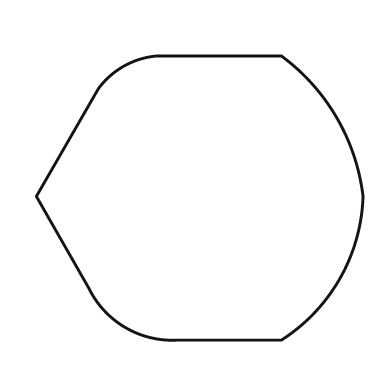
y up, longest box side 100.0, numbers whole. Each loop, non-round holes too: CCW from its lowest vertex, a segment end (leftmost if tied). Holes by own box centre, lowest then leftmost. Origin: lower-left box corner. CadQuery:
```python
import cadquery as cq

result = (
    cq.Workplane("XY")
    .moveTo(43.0, 0.0)
    .lineTo(75.0, 0.0)
    .threePointArc((93.0, 19.0), (100.0, 44.0))
    .threePointArc((92.0, 68.0), (75.0, 87.0))
    .lineTo(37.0, 87.0)
    .threePointArc((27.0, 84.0), (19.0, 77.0))
    .lineTo(0.0, 44.0)
    .lineTo(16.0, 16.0)
    .threePointArc((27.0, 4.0), (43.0, 0.0))
    .close()
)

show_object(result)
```